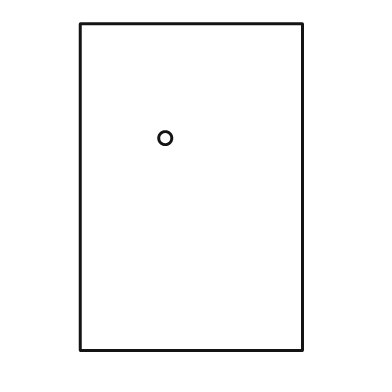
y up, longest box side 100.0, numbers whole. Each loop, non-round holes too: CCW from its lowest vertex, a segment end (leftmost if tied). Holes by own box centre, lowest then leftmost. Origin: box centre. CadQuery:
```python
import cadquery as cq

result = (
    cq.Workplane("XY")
    .moveTo(-34.0, -50.0)
    .lineTo(34.0, -50.0)
    .lineTo(34.0, 50.0)
    .lineTo(-34.0, 50.0)
    .close()
    .moveTo(-8.0, 15.0)
    .circle(2.0)
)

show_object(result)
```